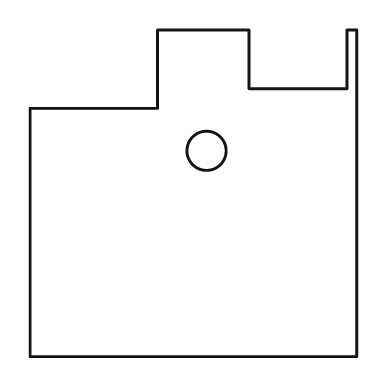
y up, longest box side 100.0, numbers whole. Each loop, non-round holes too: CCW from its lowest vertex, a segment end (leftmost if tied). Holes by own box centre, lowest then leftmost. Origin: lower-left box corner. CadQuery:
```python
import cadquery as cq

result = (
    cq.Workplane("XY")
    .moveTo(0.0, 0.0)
    .lineTo(100.0, 0.0)
    .lineTo(100.0, 100.0)
    .lineTo(97.0, 100.0)
    .lineTo(97.0, 82.0)
    .lineTo(67.0, 82.0)
    .lineTo(67.0, 100.0)
    .lineTo(39.0, 100.0)
    .lineTo(39.0, 76.0)
    .lineTo(0.0, 76.0)
    .close()
    .moveTo(54.0, 63.0)
    .circle(6.0)
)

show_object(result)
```